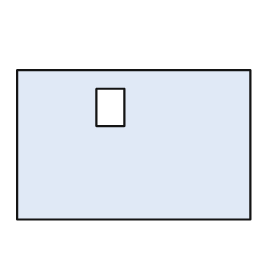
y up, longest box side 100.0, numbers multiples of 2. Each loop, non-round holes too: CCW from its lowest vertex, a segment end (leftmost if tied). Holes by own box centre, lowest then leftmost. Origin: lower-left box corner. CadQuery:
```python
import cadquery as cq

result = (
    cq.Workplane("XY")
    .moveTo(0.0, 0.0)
    .lineTo(100.0, 0.0)
    .lineTo(100.0, 64.0)
    .lineTo(0.0, 64.0)
    .close()
    .moveTo(34.0, 40.0)
    .lineTo(46.0, 40.0)
    .lineTo(46.0, 56.0)
    .lineTo(34.0, 56.0)
    .close()
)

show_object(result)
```